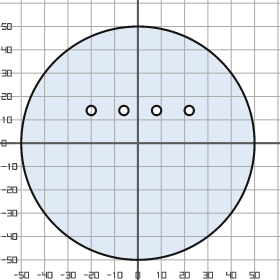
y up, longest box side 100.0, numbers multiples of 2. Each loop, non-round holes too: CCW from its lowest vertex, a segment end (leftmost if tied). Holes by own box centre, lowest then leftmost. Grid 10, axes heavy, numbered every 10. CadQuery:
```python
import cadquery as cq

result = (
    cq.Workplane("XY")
    .moveTo(0.0, 0.0)
    .circle(50.0)
    .moveTo(-20.0, 14.0)
    .circle(2.0)
    .moveTo(-6.0, 14.0)
    .circle(2.0)
    .moveTo(8.0, 14.0)
    .circle(2.0)
    .moveTo(22.0, 14.0)
    .circle(2.0)
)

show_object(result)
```